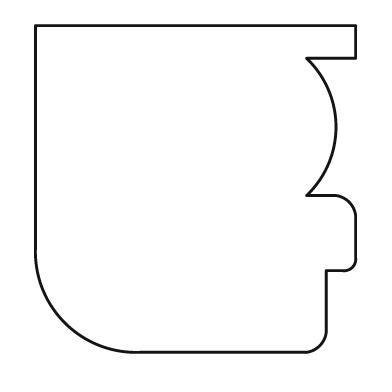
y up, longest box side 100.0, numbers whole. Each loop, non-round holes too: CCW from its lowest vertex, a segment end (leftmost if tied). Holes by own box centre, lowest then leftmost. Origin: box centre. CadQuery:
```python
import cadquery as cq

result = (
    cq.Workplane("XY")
    .moveTo(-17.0, -50.0)
    .lineTo(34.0, -50.0)
    .threePointArc((38.0, -48.0), (40.0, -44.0))
    .lineTo(40.0, -25.0)
    .lineTo(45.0, -25.0)
    .threePointArc((48.0, -24.0), (49.0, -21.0))
    .lineTo(49.0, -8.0)
    .threePointArc((47.0, -4.0), (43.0, -2.0))
    .lineTo(34.0, -2.0)
    .threePointArc((43.0, 19.0), (34.0, 40.0))
    .lineTo(49.0, 40.0)
    .lineTo(49.0, 50.0)
    .lineTo(-49.0, 50.0)
    .lineTo(-49.0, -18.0)
    .threePointArc((-40.0, -41.0), (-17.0, -50.0))
    .close()
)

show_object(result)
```